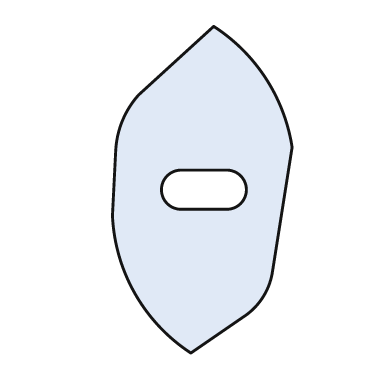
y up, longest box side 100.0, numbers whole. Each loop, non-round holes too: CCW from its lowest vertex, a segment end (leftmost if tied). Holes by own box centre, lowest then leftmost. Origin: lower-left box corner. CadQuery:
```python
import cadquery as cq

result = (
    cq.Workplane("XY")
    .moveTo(24.0, 0.0)
    .lineTo(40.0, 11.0)
    .threePointArc((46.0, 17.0), (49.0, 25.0))
    .lineTo(55.0, 63.0)
    .threePointArc((47.0, 84.0), (31.0, 100.0))
    .lineTo(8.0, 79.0)
    .threePointArc((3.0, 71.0), (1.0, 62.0))
    .lineTo(0.0, 42.0)
    .threePointArc((7.0, 18.0), (24.0, 0.0))
    .close()
    .moveTo(21.0, 44.0)
    .lineTo(35.0, 44.0)
    .threePointArc((41.0, 50.0), (35.0, 56.0))
    .lineTo(21.0, 56.0)
    .threePointArc((15.0, 50.0), (21.0, 44.0))
    .close()
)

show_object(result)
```